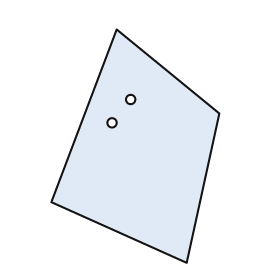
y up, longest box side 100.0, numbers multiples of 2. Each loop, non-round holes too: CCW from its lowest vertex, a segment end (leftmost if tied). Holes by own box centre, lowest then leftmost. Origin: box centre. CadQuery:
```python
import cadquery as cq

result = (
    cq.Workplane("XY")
    .moveTo(22.0, -50.0)
    .lineTo(36.0, 14.0)
    .lineTo(-8.0, 50.0)
    .lineTo(-36.0, -24.0)
    .close()
    .moveTo(-10.0, 10.0)
    .circle(2.0)
    .moveTo(-2.0, 20.0)
    .circle(2.0)
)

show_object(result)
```